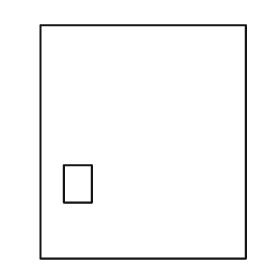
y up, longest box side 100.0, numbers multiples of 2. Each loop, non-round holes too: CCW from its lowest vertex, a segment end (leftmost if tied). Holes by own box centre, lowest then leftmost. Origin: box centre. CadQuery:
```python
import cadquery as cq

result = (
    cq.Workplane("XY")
    .moveTo(-44.0, -50.0)
    .lineTo(44.0, -50.0)
    .lineTo(44.0, 50.0)
    .lineTo(-44.0, 50.0)
    .close()
    .moveTo(-34.0, -26.0)
    .lineTo(-22.0, -26.0)
    .lineTo(-22.0, -10.0)
    .lineTo(-34.0, -10.0)
    .close()
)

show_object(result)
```